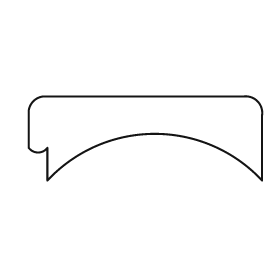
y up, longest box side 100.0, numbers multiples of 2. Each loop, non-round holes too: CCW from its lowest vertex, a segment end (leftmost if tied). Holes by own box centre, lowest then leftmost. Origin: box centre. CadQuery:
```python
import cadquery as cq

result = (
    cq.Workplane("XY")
    .moveTo(-42.0, -18.0)
    .threePointArc((4.0, 2.0), (50.0, -18.0))
    .lineTo(50.0, 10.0)
    .threePointArc((48.0, 16.0), (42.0, 18.0))
    .lineTo(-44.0, 18.0)
    .threePointArc((-48.0, 16.0), (-50.0, 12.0))
    .lineTo(-50.0, -4.0)
    .threePointArc((-46.0, -6.0), (-42.0, -4.0))
    .close()
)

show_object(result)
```